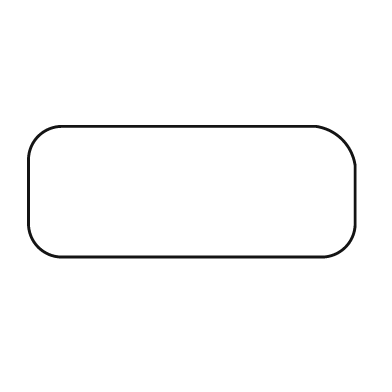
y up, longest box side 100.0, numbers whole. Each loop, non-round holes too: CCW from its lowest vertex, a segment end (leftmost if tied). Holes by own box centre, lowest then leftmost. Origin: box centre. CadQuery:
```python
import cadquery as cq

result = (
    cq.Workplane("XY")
    .moveTo(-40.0, -20.0)
    .lineTo(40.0, -20.0)
    .threePointArc((47.0, -17.0), (50.0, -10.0))
    .lineTo(50.0, 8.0)
    .threePointArc((46.0, 16.0), (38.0, 20.0))
    .lineTo(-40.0, 20.0)
    .threePointArc((-47.0, 17.0), (-50.0, 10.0))
    .lineTo(-50.0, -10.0)
    .threePointArc((-47.0, -17.0), (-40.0, -20.0))
    .close()
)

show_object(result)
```